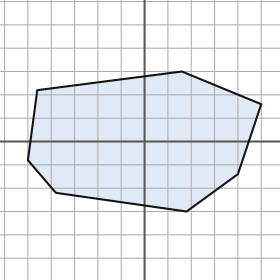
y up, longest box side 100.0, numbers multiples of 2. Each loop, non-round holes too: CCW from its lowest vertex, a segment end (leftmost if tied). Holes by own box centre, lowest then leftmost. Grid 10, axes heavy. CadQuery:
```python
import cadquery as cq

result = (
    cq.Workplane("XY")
    .moveTo(18.0, -30.0)
    .lineTo(40.0, -14.0)
    .lineTo(50.0, 16.0)
    .lineTo(16.0, 30.0)
    .lineTo(-46.0, 22.0)
    .lineTo(-50.0, -8.0)
    .lineTo(-38.0, -22.0)
    .close()
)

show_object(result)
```